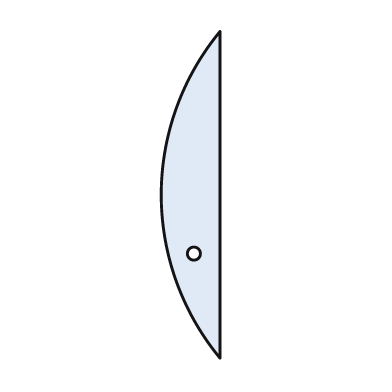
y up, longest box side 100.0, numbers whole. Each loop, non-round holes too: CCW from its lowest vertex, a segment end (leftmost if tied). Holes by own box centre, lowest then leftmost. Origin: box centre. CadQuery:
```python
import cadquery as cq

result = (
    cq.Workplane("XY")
    .moveTo(9.0, -50.0)
    .lineTo(9.0, 50.0)
    .threePointArc((-9.0, 0.0), (9.0, -50.0))
    .close()
    .moveTo(1.0, -18.0)
    .circle(2.0)
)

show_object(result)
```